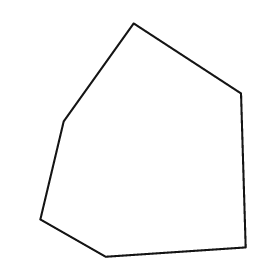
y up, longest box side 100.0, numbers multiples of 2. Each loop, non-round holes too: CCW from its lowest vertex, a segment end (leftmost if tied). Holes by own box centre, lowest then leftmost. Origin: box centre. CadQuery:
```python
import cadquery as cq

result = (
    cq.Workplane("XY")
    .moveTo(-16.0, -50.0)
    .lineTo(44.0, -46.0)
    .lineTo(42.0, 20.0)
    .lineTo(-4.0, 50.0)
    .lineTo(-34.0, 8.0)
    .lineTo(-44.0, -34.0)
    .close()
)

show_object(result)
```